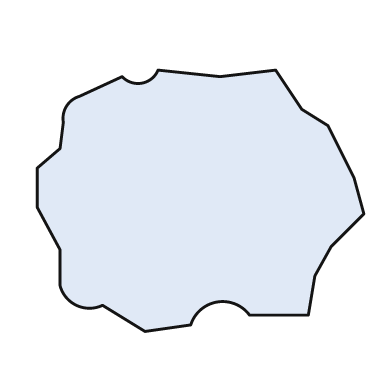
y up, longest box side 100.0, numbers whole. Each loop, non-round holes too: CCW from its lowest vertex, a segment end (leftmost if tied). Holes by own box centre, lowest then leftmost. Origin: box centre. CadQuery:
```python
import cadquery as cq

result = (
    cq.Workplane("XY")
    .moveTo(-17.0, -40.0)
    .lineTo(-3.0, -38.0)
    .threePointArc((5.0, -31.0), (15.0, -35.0))
    .lineTo(33.0, -35.0)
    .lineTo(35.0, -23.0)
    .lineTo(40.0, -14.0)
    .lineTo(50.0, -4.0)
    .lineTo(47.0, 7.0)
    .lineTo(39.0, 23.0)
    .lineTo(31.0, 28.0)
    .lineTo(23.0, 40.0)
    .lineTo(6.0, 38.0)
    .lineTo(-13.0, 40.0)
    .threePointArc((-18.0, 36.0), (-24.0, 38.0))
    .lineTo(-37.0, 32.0)
    .threePointArc((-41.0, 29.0), (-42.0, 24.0))
    .lineTo(-43.0, 16.0)
    .lineTo(-50.0, 10.0)
    .lineTo(-50.0, -2.0)
    .lineTo(-43.0, -15.0)
    .lineTo(-43.0, -26.0)
    .threePointArc((-38.0, -32.0), (-30.0, -32.0))
    .close()
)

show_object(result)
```